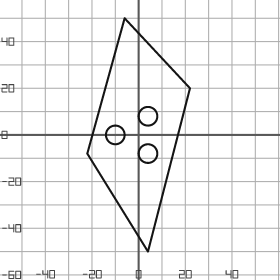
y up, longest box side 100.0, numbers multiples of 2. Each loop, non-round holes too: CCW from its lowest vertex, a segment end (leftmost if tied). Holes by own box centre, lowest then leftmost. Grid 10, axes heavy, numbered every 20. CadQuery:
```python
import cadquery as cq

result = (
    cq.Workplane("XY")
    .moveTo(4.0, -50.0)
    .lineTo(22.0, 20.0)
    .lineTo(-6.0, 50.0)
    .lineTo(-22.0, -8.0)
    .close()
    .moveTo(4.0, -8.0)
    .circle(4.0)
    .moveTo(-10.0, 0.0)
    .circle(4.0)
    .moveTo(4.0, 8.0)
    .circle(4.0)
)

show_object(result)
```